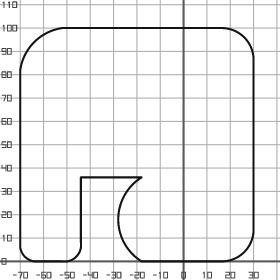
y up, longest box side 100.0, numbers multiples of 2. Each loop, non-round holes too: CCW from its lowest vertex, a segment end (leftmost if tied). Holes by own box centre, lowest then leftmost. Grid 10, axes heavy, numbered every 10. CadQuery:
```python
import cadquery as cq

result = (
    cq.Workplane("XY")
    .moveTo(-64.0, 0.0)
    .lineTo(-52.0, 0.0)
    .threePointArc((-46.0, 2.0), (-44.0, 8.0))
    .lineTo(-44.0, 36.0)
    .lineTo(-18.0, 36.0)
    .threePointArc((-28.0, 18.0), (-18.0, 0.0))
    .lineTo(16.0, 0.0)
    .threePointArc((26.0, 4.0), (30.0, 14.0))
    .lineTo(30.0, 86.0)
    .threePointArc((26.0, 96.0), (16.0, 100.0))
    .lineTo(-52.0, 100.0)
    .threePointArc((-64.0, 94.0), (-70.0, 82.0))
    .lineTo(-70.0, 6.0)
    .threePointArc((-68.0, 2.0), (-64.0, 0.0))
    .close()
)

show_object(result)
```